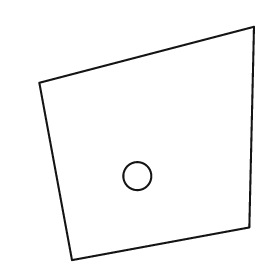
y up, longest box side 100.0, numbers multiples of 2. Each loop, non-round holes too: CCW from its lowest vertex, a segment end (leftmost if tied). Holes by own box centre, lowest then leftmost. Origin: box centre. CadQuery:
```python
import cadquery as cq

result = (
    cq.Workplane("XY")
    .moveTo(-32.0, -50.0)
    .lineTo(44.0, -36.0)
    .lineTo(46.0, 50.0)
    .lineTo(-46.0, 26.0)
    .close()
    .moveTo(-4.0, -14.0)
    .circle(6.0)
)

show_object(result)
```